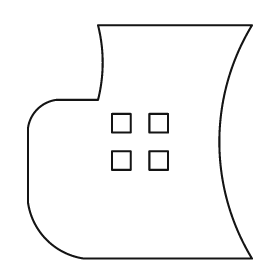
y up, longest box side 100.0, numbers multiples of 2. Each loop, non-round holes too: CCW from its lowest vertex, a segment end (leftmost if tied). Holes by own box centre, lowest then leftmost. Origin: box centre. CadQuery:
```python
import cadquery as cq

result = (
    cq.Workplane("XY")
    .moveTo(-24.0, -50.0)
    .lineTo(48.0, -50.0)
    .threePointArc((34.0, 0.0), (48.0, 50.0))
    .lineTo(-18.0, 50.0)
    .threePointArc((-16.0, 34.0), (-18.0, 18.0))
    .lineTo(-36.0, 18.0)
    .threePointArc((-44.0, 14.0), (-48.0, 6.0))
    .lineTo(-48.0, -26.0)
    .threePointArc((-40.0, -42.0), (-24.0, -50.0))
    .close()
    .moveTo(-12.0, -12.0)
    .lineTo(-4.0, -12.0)
    .lineTo(-4.0, -4.0)
    .lineTo(-12.0, -4.0)
    .close()
    .moveTo(4.0, -12.0)
    .lineTo(12.0, -12.0)
    .lineTo(12.0, -4.0)
    .lineTo(4.0, -4.0)
    .close()
    .moveTo(-12.0, 4.0)
    .lineTo(-4.0, 4.0)
    .lineTo(-4.0, 12.0)
    .lineTo(-12.0, 12.0)
    .close()
    .moveTo(4.0, 4.0)
    .lineTo(12.0, 4.0)
    .lineTo(12.0, 12.0)
    .lineTo(4.0, 12.0)
    .close()
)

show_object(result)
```